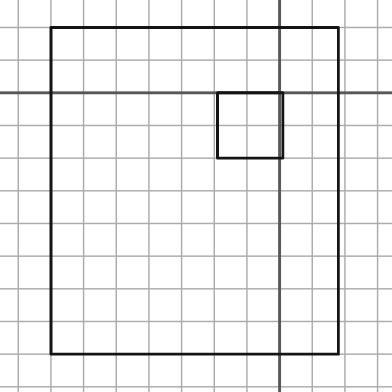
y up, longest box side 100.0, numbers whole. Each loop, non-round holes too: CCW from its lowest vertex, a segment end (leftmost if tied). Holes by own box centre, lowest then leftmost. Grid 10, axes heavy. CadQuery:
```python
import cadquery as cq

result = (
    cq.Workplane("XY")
    .moveTo(-70.0, -80.0)
    .lineTo(18.0, -80.0)
    .lineTo(18.0, 20.0)
    .lineTo(-70.0, 20.0)
    .close()
    .moveTo(-19.0, -20.0)
    .lineTo(1.0, -20.0)
    .lineTo(1.0, 0.0)
    .lineTo(-19.0, 0.0)
    .close()
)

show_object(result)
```